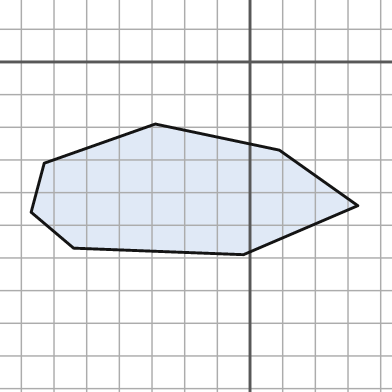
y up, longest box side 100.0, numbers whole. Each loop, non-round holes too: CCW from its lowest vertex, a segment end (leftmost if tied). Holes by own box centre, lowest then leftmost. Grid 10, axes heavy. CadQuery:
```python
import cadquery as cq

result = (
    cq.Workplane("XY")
    .moveTo(-2.0, -59.0)
    .lineTo(33.0, -44.0)
    .lineTo(9.0, -27.0)
    .lineTo(-29.0, -19.0)
    .lineTo(-63.0, -31.0)
    .lineTo(-67.0, -46.0)
    .lineTo(-54.0, -57.0)
    .close()
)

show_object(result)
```